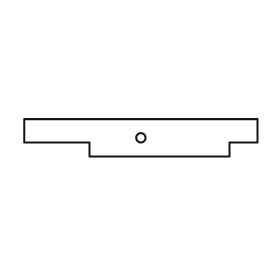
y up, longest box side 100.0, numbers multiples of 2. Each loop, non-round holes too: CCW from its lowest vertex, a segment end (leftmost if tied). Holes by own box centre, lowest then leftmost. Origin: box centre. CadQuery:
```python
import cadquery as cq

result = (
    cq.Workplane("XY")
    .moveTo(-22.0, -8.0)
    .lineTo(38.0, -8.0)
    .lineTo(38.0, -2.0)
    .lineTo(50.0, -2.0)
    .lineTo(50.0, 8.0)
    .lineTo(-50.0, 8.0)
    .lineTo(-50.0, -2.0)
    .lineTo(-22.0, -2.0)
    .close()
    .moveTo(0.0, 0.0)
    .circle(2.0)
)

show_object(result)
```